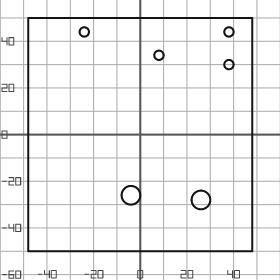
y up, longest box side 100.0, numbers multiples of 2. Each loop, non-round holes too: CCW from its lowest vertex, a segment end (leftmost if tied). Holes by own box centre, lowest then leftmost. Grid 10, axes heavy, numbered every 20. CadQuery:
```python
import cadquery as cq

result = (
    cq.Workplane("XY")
    .moveTo(-48.0, -50.0)
    .lineTo(48.0, -50.0)
    .lineTo(48.0, 50.0)
    .lineTo(-48.0, 50.0)
    .close()
    .moveTo(26.0, -28.0)
    .circle(4.0)
    .moveTo(-4.0, -26.0)
    .circle(4.0)
    .moveTo(38.0, 30.0)
    .circle(2.0)
    .moveTo(8.0, 34.0)
    .circle(2.0)
    .moveTo(-24.0, 44.0)
    .circle(2.0)
    .moveTo(38.0, 44.0)
    .circle(2.0)
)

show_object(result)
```